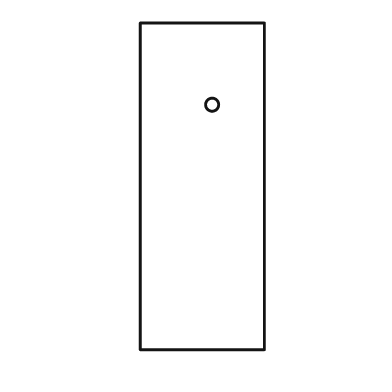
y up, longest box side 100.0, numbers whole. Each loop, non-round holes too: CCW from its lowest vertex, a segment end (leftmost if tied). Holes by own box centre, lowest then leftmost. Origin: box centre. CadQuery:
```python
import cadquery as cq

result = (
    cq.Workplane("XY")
    .moveTo(-19.0, -50.0)
    .lineTo(19.0, -50.0)
    .lineTo(19.0, 50.0)
    .lineTo(-19.0, 50.0)
    .close()
    .moveTo(3.0, 25.0)
    .circle(2.0)
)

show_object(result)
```